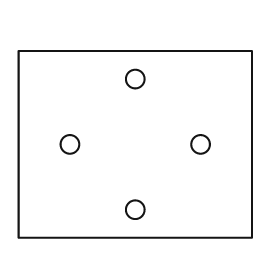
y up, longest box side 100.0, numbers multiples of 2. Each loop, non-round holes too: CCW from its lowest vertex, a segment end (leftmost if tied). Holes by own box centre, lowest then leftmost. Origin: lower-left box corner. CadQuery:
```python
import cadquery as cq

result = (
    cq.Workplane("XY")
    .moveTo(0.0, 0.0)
    .lineTo(100.0, 0.0)
    .lineTo(100.0, 80.0)
    .lineTo(0.0, 80.0)
    .close()
    .moveTo(50.0, 12.0)
    .circle(4.0)
    .moveTo(22.0, 40.0)
    .circle(4.0)
    .moveTo(78.0, 40.0)
    .circle(4.0)
    .moveTo(50.0, 68.0)
    .circle(4.0)
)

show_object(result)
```